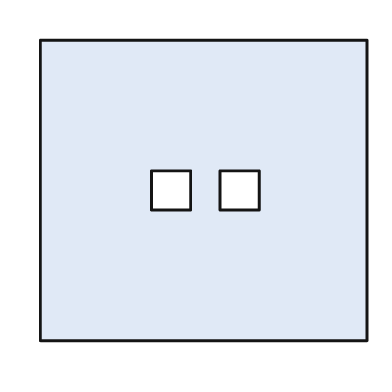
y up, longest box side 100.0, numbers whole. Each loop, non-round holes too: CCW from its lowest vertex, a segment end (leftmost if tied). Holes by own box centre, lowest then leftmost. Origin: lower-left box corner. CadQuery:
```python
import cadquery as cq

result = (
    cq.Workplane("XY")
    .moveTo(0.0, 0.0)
    .lineTo(100.0, 0.0)
    .lineTo(100.0, 92.0)
    .lineTo(0.0, 92.0)
    .close()
    .moveTo(34.0, 40.0)
    .lineTo(46.0, 40.0)
    .lineTo(46.0, 52.0)
    .lineTo(34.0, 52.0)
    .close()
    .moveTo(55.0, 40.0)
    .lineTo(67.0, 40.0)
    .lineTo(67.0, 52.0)
    .lineTo(55.0, 52.0)
    .close()
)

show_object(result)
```